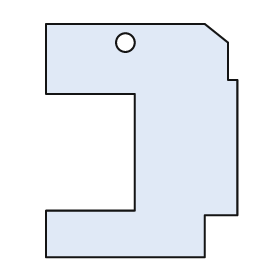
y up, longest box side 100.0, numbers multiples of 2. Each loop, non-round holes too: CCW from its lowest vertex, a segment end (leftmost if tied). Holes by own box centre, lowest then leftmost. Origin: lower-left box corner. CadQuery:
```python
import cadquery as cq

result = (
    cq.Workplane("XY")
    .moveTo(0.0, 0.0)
    .lineTo(68.0, 0.0)
    .lineTo(68.0, 18.0)
    .lineTo(82.0, 18.0)
    .lineTo(82.0, 76.0)
    .lineTo(78.0, 76.0)
    .lineTo(78.0, 92.0)
    .lineTo(68.0, 100.0)
    .lineTo(0.0, 100.0)
    .lineTo(0.0, 70.0)
    .lineTo(38.0, 70.0)
    .lineTo(38.0, 20.0)
    .lineTo(0.0, 20.0)
    .close()
    .moveTo(34.0, 92.0)
    .circle(4.0)
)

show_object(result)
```